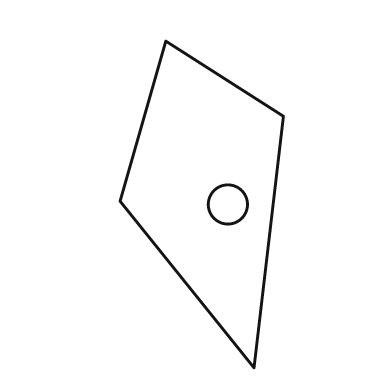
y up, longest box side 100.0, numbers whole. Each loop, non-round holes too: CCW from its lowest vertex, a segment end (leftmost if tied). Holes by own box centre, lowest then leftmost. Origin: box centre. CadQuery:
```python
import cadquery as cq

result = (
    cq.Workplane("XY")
    .moveTo(16.0, -50.0)
    .lineTo(25.0, 27.0)
    .lineTo(-11.0, 50.0)
    .lineTo(-25.0, 1.0)
    .close()
    .moveTo(8.0, 0.0)
    .circle(6.0)
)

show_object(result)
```